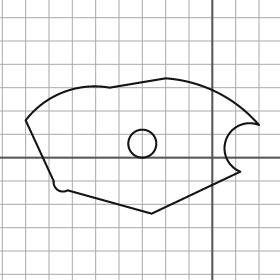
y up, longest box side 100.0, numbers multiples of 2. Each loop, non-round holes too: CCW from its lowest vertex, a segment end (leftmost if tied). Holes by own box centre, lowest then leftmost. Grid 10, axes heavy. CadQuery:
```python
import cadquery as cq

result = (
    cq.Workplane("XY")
    .moveTo(-26.0, -24.0)
    .lineTo(12.0, -6.0)
    .threePointArc((6.0, 8.0), (20.0, 14.0))
    .threePointArc((2.0, 28.0), (-20.0, 34.0))
    .lineTo(-44.0, 30.0)
    .threePointArc((-64.0, 28.0), (-80.0, 16.0))
    .lineTo(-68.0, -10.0)
    .threePointArc((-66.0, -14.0), (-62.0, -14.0))
    .close()
    .moveTo(-30.0, 6.0)
    .circle(6.0)
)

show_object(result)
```